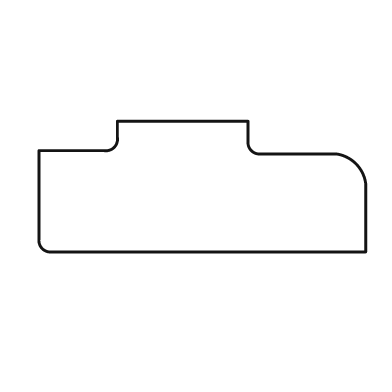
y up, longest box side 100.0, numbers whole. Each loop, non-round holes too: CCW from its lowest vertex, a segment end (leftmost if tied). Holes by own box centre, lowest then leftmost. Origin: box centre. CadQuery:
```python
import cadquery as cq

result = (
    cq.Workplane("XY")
    .moveTo(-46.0, -20.0)
    .lineTo(50.0, -20.0)
    .lineTo(50.0, 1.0)
    .threePointArc((47.0, 7.0), (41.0, 10.0))
    .lineTo(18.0, 10.0)
    .threePointArc((15.0, 11.0), (14.0, 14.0))
    .lineTo(14.0, 20.0)
    .lineTo(-26.0, 20.0)
    .lineTo(-26.0, 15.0)
    .threePointArc((-27.0, 12.0), (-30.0, 11.0))
    .lineTo(-50.0, 11.0)
    .lineTo(-50.0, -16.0)
    .threePointArc((-49.0, -19.0), (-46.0, -20.0))
    .close()
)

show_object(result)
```